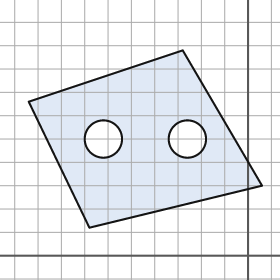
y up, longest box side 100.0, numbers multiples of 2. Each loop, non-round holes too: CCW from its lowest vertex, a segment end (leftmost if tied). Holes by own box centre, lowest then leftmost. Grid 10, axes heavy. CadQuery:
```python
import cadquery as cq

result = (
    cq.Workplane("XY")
    .moveTo(-68.0, 12.0)
    .lineTo(6.0, 30.0)
    .lineTo(-28.0, 88.0)
    .lineTo(-94.0, 66.0)
    .close()
    .moveTo(-62.0, 50.0)
    .circle(8.0)
    .moveTo(-26.0, 50.0)
    .circle(8.0)
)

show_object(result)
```